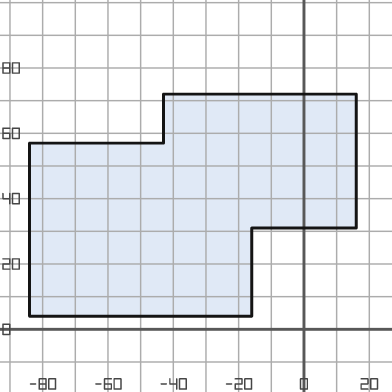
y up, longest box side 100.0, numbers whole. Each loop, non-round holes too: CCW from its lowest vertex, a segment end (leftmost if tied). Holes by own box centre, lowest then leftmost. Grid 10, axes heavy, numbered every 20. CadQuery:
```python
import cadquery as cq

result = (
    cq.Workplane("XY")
    .moveTo(-84.0, 4.0)
    .lineTo(-16.0, 4.0)
    .lineTo(-16.0, 31.0)
    .lineTo(16.0, 31.0)
    .lineTo(16.0, 72.0)
    .lineTo(-43.0, 72.0)
    .lineTo(-43.0, 57.0)
    .lineTo(-84.0, 57.0)
    .close()
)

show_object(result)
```